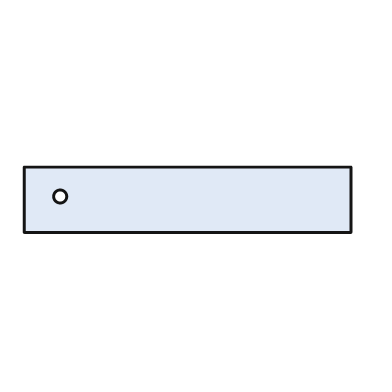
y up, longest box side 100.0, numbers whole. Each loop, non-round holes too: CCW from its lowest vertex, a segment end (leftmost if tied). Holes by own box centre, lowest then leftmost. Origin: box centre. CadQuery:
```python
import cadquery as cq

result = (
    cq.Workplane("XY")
    .moveTo(-50.0, -10.0)
    .lineTo(50.0, -10.0)
    .lineTo(50.0, 10.0)
    .lineTo(-50.0, 10.0)
    .close()
    .moveTo(-39.0, 1.0)
    .circle(2.0)
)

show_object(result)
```